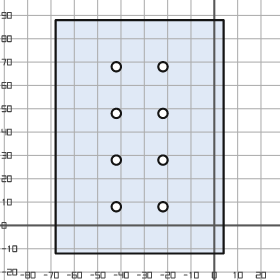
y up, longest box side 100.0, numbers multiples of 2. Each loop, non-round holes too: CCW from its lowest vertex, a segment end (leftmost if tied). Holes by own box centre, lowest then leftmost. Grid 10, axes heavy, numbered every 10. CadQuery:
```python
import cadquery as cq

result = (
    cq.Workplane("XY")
    .moveTo(-68.0, -12.0)
    .lineTo(4.0, -12.0)
    .lineTo(4.0, 88.0)
    .lineTo(-68.0, 88.0)
    .close()
    .moveTo(-42.0, 8.0)
    .circle(2.0)
    .moveTo(-22.0, 8.0)
    .circle(2.0)
    .moveTo(-42.0, 28.0)
    .circle(2.0)
    .moveTo(-22.0, 28.0)
    .circle(2.0)
    .moveTo(-42.0, 48.0)
    .circle(2.0)
    .moveTo(-22.0, 48.0)
    .circle(2.0)
    .moveTo(-42.0, 68.0)
    .circle(2.0)
    .moveTo(-22.0, 68.0)
    .circle(2.0)
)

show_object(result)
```